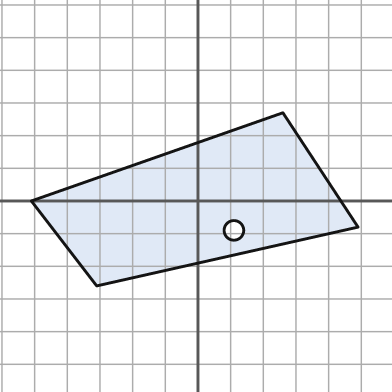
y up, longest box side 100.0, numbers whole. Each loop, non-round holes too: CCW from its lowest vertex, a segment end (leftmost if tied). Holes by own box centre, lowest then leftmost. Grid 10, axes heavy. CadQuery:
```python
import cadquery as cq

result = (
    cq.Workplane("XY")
    .moveTo(-31.0, -26.0)
    .lineTo(49.0, -8.0)
    .lineTo(26.0, 27.0)
    .lineTo(-51.0, 0.0)
    .close()
    .moveTo(11.0, -9.0)
    .circle(3.0)
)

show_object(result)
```